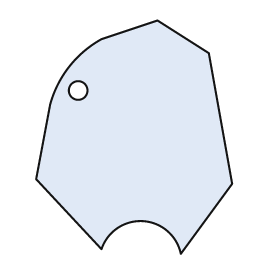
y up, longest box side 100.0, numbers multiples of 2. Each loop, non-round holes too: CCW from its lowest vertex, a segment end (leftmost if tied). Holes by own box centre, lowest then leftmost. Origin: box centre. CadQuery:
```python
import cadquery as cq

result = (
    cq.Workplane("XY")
    .moveTo(20.0, -50.0)
    .lineTo(42.0, -20.0)
    .lineTo(32.0, 36.0)
    .lineTo(10.0, 50.0)
    .lineTo(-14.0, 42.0)
    .threePointArc((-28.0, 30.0), (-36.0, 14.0))
    .lineTo(-42.0, -18.0)
    .lineTo(-14.0, -48.0)
    .threePointArc((4.0, -36.0), (20.0, -50.0))
    .close()
    .moveTo(-24.0, 20.0)
    .circle(4.0)
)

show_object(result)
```